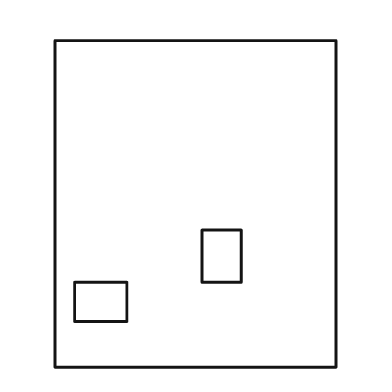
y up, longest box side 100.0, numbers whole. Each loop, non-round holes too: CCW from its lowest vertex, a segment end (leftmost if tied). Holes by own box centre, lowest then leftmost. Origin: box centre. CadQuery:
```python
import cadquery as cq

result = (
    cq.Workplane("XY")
    .moveTo(-43.0, -50.0)
    .lineTo(43.0, -50.0)
    .lineTo(43.0, 50.0)
    .lineTo(-43.0, 50.0)
    .close()
    .moveTo(-37.0, -36.0)
    .lineTo(-21.0, -36.0)
    .lineTo(-21.0, -24.0)
    .lineTo(-37.0, -24.0)
    .close()
    .moveTo(2.0, -24.0)
    .lineTo(14.0, -24.0)
    .lineTo(14.0, -8.0)
    .lineTo(2.0, -8.0)
    .close()
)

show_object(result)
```